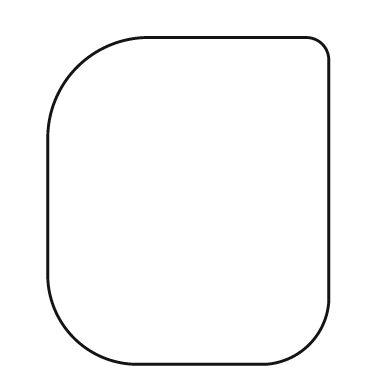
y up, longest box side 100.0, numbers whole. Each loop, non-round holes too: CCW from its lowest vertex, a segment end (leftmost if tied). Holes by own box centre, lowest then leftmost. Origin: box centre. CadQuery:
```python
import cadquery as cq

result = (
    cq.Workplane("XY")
    .moveTo(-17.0, -50.0)
    .lineTo(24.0, -50.0)
    .threePointArc((37.0, -44.0), (43.0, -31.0))
    .lineTo(43.0, 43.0)
    .threePointArc((41.0, 48.0), (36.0, 50.0))
    .lineTo(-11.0, 50.0)
    .threePointArc((-34.0, 41.0), (-43.0, 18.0))
    .lineTo(-43.0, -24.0)
    .threePointArc((-35.0, -42.0), (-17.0, -50.0))
    .close()
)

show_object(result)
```